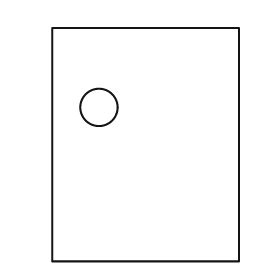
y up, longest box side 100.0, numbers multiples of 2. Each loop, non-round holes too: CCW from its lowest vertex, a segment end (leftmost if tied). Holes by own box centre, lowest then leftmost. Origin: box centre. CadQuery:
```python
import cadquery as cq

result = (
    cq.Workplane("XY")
    .moveTo(-40.0, -50.0)
    .lineTo(40.0, -50.0)
    .lineTo(40.0, 50.0)
    .lineTo(-40.0, 50.0)
    .close()
    .moveTo(-20.0, 16.0)
    .circle(8.0)
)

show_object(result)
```